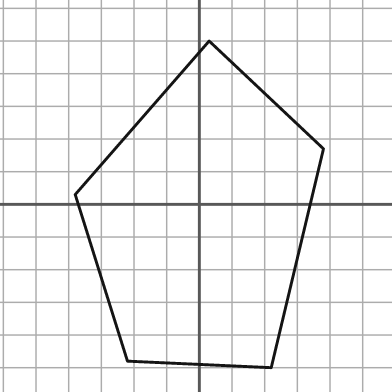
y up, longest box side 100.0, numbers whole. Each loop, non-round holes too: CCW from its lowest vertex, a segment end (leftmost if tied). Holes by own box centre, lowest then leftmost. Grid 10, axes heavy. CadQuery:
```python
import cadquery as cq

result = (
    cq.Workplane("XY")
    .moveTo(22.0, -50.0)
    .lineTo(38.0, 17.0)
    .lineTo(3.0, 50.0)
    .lineTo(-38.0, 3.0)
    .lineTo(-22.0, -48.0)
    .close()
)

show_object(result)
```